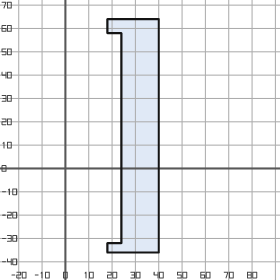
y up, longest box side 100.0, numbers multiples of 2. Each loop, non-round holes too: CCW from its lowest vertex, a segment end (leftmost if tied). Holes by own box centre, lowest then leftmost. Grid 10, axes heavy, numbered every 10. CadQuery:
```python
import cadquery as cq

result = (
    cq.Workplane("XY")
    .moveTo(18.0, -36.0)
    .lineTo(40.0, -36.0)
    .lineTo(40.0, 64.0)
    .lineTo(18.0, 64.0)
    .lineTo(18.0, 58.0)
    .lineTo(24.0, 58.0)
    .lineTo(24.0, -32.0)
    .lineTo(18.0, -32.0)
    .close()
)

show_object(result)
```